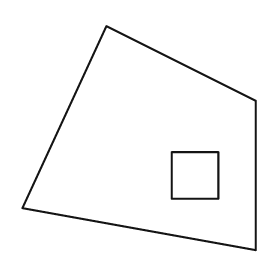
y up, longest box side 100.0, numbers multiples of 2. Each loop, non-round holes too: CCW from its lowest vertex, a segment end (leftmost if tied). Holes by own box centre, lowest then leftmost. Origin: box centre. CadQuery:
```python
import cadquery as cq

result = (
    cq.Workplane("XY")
    .moveTo(50.0, -48.0)
    .lineTo(50.0, 16.0)
    .lineTo(-14.0, 48.0)
    .lineTo(-50.0, -30.0)
    .close()
    .moveTo(14.0, -26.0)
    .lineTo(34.0, -26.0)
    .lineTo(34.0, -6.0)
    .lineTo(14.0, -6.0)
    .close()
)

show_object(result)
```